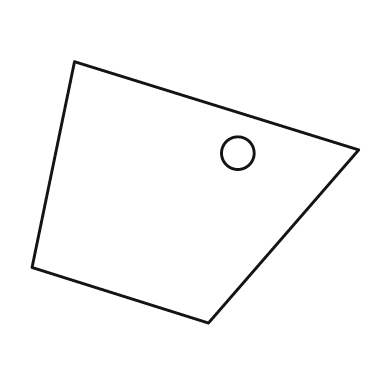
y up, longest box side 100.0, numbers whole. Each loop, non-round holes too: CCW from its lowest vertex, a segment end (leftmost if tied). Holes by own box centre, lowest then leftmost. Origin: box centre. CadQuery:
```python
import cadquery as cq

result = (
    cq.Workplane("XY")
    .moveTo(4.0, -40.0)
    .lineTo(50.0, 13.0)
    .lineTo(-37.0, 40.0)
    .lineTo(-50.0, -23.0)
    .close()
    .moveTo(13.0, 12.0)
    .circle(5.0)
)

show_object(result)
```